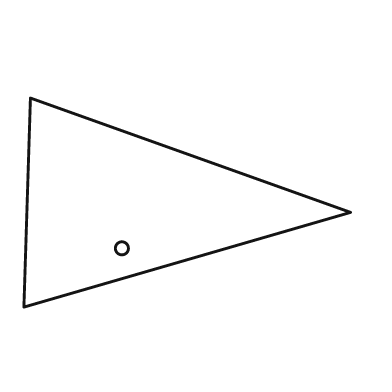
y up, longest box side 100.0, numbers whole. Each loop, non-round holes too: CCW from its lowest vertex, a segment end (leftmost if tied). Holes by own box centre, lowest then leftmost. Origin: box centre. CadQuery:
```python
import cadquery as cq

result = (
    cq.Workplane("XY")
    .moveTo(-50.0, -32.0)
    .lineTo(50.0, -3.0)
    .lineTo(-48.0, 32.0)
    .close()
    .moveTo(-20.0, -14.0)
    .circle(2.0)
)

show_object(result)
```